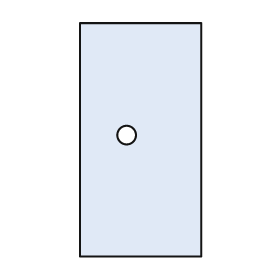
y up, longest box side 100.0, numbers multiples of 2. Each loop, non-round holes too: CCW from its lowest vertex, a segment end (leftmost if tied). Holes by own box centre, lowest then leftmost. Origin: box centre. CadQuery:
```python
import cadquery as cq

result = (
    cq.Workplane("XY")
    .moveTo(-26.0, -50.0)
    .lineTo(26.0, -50.0)
    .lineTo(26.0, 50.0)
    .lineTo(-26.0, 50.0)
    .close()
    .moveTo(-6.0, 2.0)
    .circle(4.0)
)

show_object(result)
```